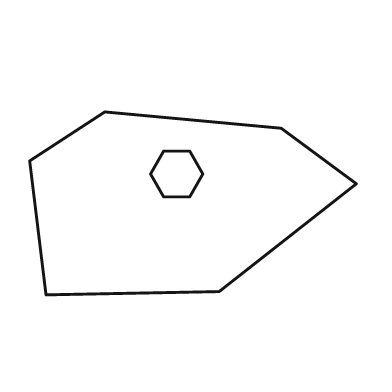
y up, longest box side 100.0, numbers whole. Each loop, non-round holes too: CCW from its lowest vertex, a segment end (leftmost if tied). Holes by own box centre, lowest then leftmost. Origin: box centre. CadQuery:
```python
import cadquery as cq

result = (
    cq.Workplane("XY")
    .moveTo(-45.0, -28.0)
    .lineTo(8.0, -27.0)
    .lineTo(50.0, 6.0)
    .lineTo(27.0, 23.0)
    .lineTo(-27.0, 28.0)
    .lineTo(-50.0, 13.0)
    .close()
    .moveTo(-9.0, 2.0)
    .lineTo(-1.0, 2.0)
    .lineTo(3.0, 9.0)
    .lineTo(-1.0, 16.0)
    .lineTo(-9.0, 16.0)
    .lineTo(-13.0, 9.0)
    .close()
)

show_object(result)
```